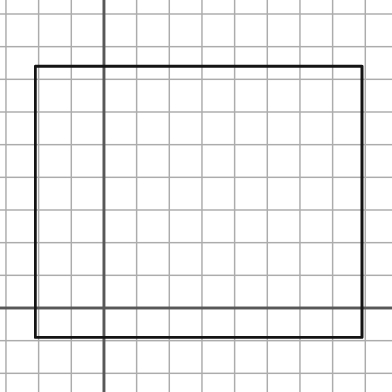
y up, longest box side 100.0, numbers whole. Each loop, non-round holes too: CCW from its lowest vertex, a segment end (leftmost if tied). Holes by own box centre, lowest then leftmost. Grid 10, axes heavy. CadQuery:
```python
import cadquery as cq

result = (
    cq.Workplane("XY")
    .moveTo(-21.0, -9.0)
    .lineTo(79.0, -9.0)
    .lineTo(79.0, 74.0)
    .lineTo(-21.0, 74.0)
    .close()
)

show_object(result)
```